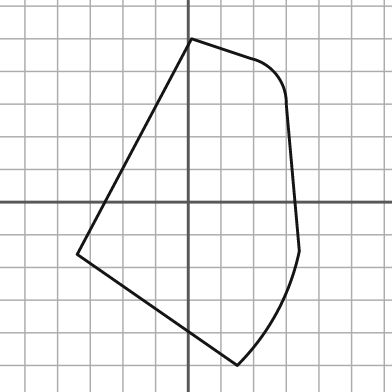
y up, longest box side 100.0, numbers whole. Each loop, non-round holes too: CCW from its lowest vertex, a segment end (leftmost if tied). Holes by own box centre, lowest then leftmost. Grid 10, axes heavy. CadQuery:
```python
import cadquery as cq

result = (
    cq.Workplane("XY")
    .moveTo(15.0, -50.0)
    .threePointArc((27.0, -34.0), (34.0, -15.0))
    .lineTo(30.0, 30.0)
    .threePointArc((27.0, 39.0), (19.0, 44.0))
    .lineTo(1.0, 50.0)
    .lineTo(-34.0, -16.0)
    .close()
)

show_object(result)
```